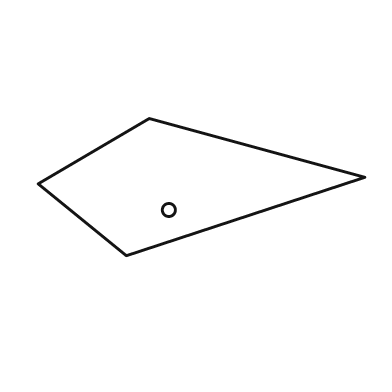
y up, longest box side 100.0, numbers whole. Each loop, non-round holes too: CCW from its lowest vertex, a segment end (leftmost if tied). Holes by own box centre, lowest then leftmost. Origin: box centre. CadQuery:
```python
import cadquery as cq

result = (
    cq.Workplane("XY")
    .moveTo(-23.0, -21.0)
    .lineTo(50.0, 3.0)
    .lineTo(-16.0, 21.0)
    .lineTo(-50.0, 1.0)
    .close()
    .moveTo(-10.0, -7.0)
    .circle(2.0)
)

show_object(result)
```